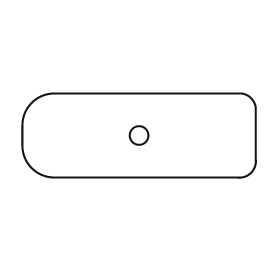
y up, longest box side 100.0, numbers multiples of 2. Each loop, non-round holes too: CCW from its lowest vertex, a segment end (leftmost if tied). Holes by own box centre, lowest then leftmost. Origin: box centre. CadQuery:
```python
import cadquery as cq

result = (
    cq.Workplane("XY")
    .moveTo(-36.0, -18.0)
    .lineTo(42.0, -18.0)
    .threePointArc((48.0, -16.0), (50.0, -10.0))
    .lineTo(50.0, 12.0)
    .threePointArc((48.0, 16.0), (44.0, 18.0))
    .lineTo(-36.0, 18.0)
    .threePointArc((-46.0, 14.0), (-50.0, 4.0))
    .lineTo(-50.0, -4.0)
    .threePointArc((-46.0, -14.0), (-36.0, -18.0))
    .close()
    .moveTo(0.0, 0.0)
    .circle(4.0)
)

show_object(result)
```